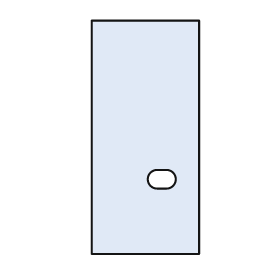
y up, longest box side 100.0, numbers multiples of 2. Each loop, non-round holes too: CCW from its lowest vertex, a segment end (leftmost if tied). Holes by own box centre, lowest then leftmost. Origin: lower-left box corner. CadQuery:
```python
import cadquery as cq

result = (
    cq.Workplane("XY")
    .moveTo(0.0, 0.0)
    .lineTo(46.0, 0.0)
    .lineTo(46.0, 100.0)
    .lineTo(0.0, 100.0)
    .close()
    .moveTo(28.0, 28.0)
    .lineTo(32.0, 28.0)
    .threePointArc((36.0, 32.0), (32.0, 36.0))
    .lineTo(28.0, 36.0)
    .threePointArc((24.0, 32.0), (28.0, 28.0))
    .close()
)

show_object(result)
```